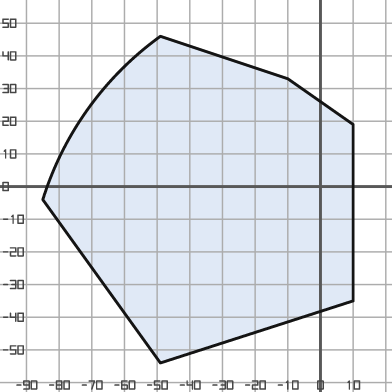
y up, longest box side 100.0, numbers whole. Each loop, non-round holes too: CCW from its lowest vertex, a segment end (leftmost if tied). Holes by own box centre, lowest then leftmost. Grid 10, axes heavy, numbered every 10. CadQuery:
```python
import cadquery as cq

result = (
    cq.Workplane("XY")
    .moveTo(-49.0, -54.0)
    .lineTo(10.0, -35.0)
    .lineTo(10.0, 19.0)
    .lineTo(-10.0, 33.0)
    .lineTo(-49.0, 46.0)
    .threePointArc((-71.0, 24.0), (-85.0, -4.0))
    .close()
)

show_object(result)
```